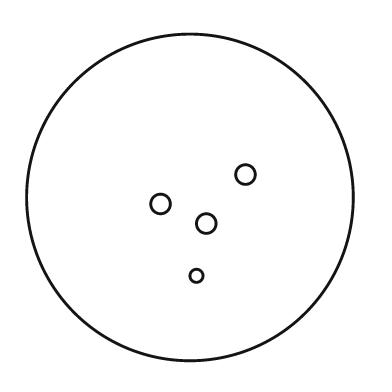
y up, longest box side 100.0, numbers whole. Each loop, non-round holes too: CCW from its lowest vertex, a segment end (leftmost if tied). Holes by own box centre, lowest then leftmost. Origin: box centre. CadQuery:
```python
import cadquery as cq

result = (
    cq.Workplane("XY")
    .moveTo(0.0, 0.0)
    .circle(50.0)
    .moveTo(2.0, -24.0)
    .circle(2.0)
    .moveTo(5.0, -8.0)
    .circle(3.0)
    .moveTo(-9.0, -2.0)
    .circle(3.0)
    .moveTo(17.0, 7.0)
    .circle(3.0)
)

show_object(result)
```